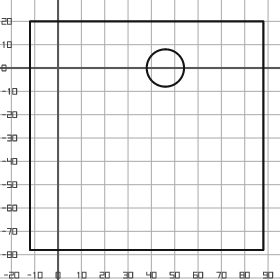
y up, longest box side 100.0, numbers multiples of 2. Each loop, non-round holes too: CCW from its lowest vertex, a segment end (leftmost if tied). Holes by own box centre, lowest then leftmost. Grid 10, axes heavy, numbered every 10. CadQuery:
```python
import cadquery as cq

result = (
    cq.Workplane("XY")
    .moveTo(-12.0, -78.0)
    .lineTo(88.0, -78.0)
    .lineTo(88.0, 20.0)
    .lineTo(-12.0, 20.0)
    .close()
    .moveTo(46.0, 0.0)
    .circle(8.0)
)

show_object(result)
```